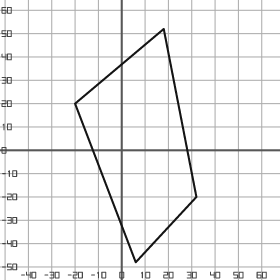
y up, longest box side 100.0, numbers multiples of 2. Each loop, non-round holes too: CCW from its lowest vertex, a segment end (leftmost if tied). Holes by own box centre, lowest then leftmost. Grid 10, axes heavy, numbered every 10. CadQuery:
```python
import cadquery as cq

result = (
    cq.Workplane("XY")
    .moveTo(6.0, -48.0)
    .lineTo(32.0, -20.0)
    .lineTo(18.0, 52.0)
    .lineTo(-20.0, 20.0)
    .close()
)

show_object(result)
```